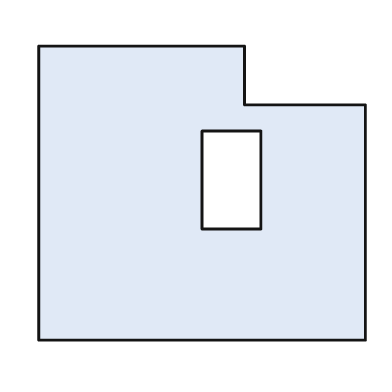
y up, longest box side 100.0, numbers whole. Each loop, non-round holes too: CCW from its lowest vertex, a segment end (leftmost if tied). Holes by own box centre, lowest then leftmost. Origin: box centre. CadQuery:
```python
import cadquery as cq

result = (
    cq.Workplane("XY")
    .moveTo(-50.0, -45.0)
    .lineTo(50.0, -45.0)
    .lineTo(50.0, 27.0)
    .lineTo(13.0, 27.0)
    .lineTo(13.0, 45.0)
    .lineTo(-50.0, 45.0)
    .close()
    .moveTo(0.0, -11.0)
    .lineTo(18.0, -11.0)
    .lineTo(18.0, 19.0)
    .lineTo(0.0, 19.0)
    .close()
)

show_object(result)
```